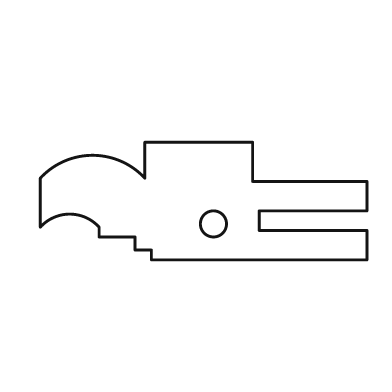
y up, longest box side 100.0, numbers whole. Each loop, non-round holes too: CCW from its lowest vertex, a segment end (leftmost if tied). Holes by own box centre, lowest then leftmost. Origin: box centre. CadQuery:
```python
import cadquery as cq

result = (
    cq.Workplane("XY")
    .moveTo(-16.0, -18.0)
    .lineTo(50.0, -18.0)
    .lineTo(50.0, -9.0)
    .lineTo(17.0, -9.0)
    .lineTo(17.0, -3.0)
    .lineTo(50.0, -3.0)
    .lineTo(50.0, 6.0)
    .lineTo(15.0, 6.0)
    .lineTo(15.0, 18.0)
    .lineTo(-18.0, 18.0)
    .lineTo(-18.0, 7.0)
    .threePointArc((-34.0, 14.0), (-50.0, 7.0))
    .lineTo(-50.0, -8.0)
    .threePointArc((-41.0, -4.0), (-32.0, -8.0))
    .lineTo(-32.0, -11.0)
    .lineTo(-21.0, -11.0)
    .lineTo(-21.0, -15.0)
    .lineTo(-16.0, -15.0)
    .close()
    .moveTo(3.0, -7.0)
    .circle(4.0)
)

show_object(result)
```